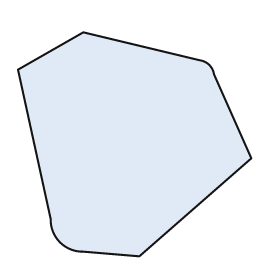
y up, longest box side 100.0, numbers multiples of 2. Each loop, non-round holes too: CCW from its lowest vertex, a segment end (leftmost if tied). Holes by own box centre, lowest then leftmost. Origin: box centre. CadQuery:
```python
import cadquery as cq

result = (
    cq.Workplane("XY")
    .moveTo(2.0, -48.0)
    .lineTo(50.0, -6.0)
    .lineTo(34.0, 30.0)
    .threePointArc((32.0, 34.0), (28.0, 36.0))
    .lineTo(-22.0, 48.0)
    .lineTo(-50.0, 32.0)
    .lineTo(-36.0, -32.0)
    .threePointArc((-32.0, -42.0), (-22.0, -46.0))
    .close()
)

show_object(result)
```